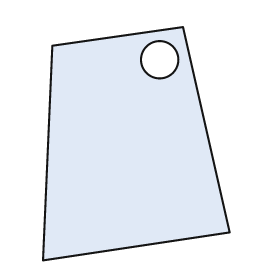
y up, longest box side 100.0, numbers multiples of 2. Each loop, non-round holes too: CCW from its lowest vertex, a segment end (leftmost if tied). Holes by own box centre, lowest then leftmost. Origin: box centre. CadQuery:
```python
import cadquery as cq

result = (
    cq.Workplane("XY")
    .moveTo(-40.0, -50.0)
    .lineTo(40.0, -38.0)
    .lineTo(20.0, 50.0)
    .lineTo(-36.0, 42.0)
    .close()
    .moveTo(10.0, 36.0)
    .circle(8.0)
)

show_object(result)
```